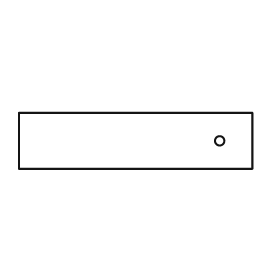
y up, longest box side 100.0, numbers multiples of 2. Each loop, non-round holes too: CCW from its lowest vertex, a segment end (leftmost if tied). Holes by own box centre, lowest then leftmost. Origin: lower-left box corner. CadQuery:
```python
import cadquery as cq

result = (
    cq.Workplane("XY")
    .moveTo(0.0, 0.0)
    .lineTo(100.0, 0.0)
    .lineTo(100.0, 24.0)
    .lineTo(0.0, 24.0)
    .close()
    .moveTo(86.0, 12.0)
    .circle(2.0)
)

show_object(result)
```